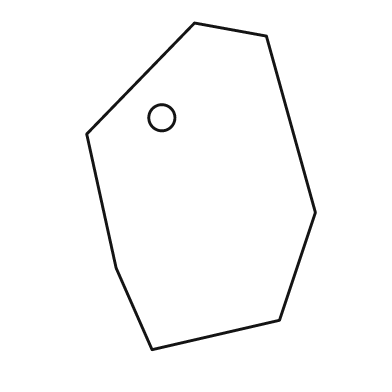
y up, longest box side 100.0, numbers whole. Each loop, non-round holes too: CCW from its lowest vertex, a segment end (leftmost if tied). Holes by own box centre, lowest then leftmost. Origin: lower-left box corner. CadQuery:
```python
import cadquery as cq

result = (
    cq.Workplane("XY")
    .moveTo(20.0, 0.0)
    .lineTo(59.0, 9.0)
    .lineTo(70.0, 42.0)
    .lineTo(55.0, 96.0)
    .lineTo(33.0, 100.0)
    .lineTo(0.0, 66.0)
    .lineTo(9.0, 25.0)
    .close()
    .moveTo(23.0, 71.0)
    .circle(4.0)
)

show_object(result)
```